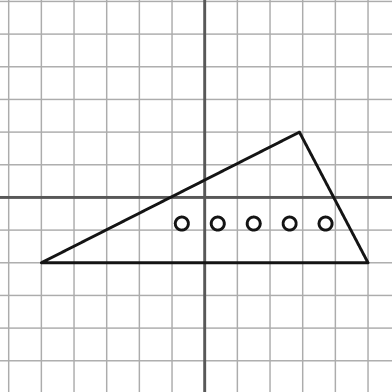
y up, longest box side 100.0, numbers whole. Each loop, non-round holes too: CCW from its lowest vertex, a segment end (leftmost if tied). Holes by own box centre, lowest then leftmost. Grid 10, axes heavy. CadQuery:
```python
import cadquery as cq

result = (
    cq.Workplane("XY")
    .moveTo(-50.0, -20.0)
    .lineTo(50.0, -20.0)
    .lineTo(29.0, 20.0)
    .close()
    .moveTo(-7.0, -8.0)
    .circle(2.0)
    .moveTo(4.0, -8.0)
    .circle(2.0)
    .moveTo(15.0, -8.0)
    .circle(2.0)
    .moveTo(26.0, -8.0)
    .circle(2.0)
    .moveTo(37.0, -8.0)
    .circle(2.0)
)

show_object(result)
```